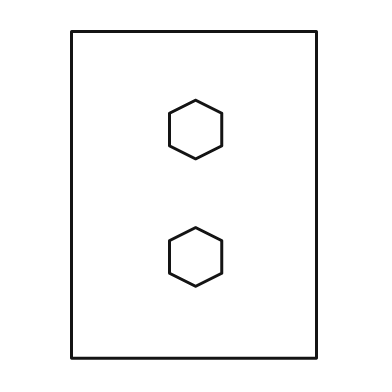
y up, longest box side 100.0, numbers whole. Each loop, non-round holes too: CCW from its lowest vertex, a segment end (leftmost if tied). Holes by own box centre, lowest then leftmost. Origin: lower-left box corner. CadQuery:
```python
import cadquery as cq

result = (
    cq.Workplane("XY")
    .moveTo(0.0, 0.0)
    .lineTo(75.0, 0.0)
    .lineTo(75.0, 100.0)
    .lineTo(0.0, 100.0)
    .close()
    .moveTo(38.0, 22.0)
    .lineTo(46.0, 26.0)
    .lineTo(46.0, 36.0)
    .lineTo(38.0, 40.0)
    .lineTo(30.0, 36.0)
    .lineTo(30.0, 26.0)
    .close()
    .moveTo(38.0, 61.0)
    .lineTo(46.0, 65.0)
    .lineTo(46.0, 75.0)
    .lineTo(38.0, 79.0)
    .lineTo(30.0, 75.0)
    .lineTo(30.0, 65.0)
    .close()
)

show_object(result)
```